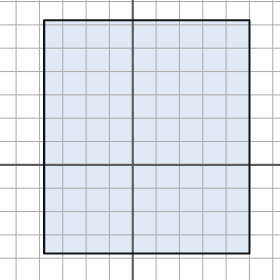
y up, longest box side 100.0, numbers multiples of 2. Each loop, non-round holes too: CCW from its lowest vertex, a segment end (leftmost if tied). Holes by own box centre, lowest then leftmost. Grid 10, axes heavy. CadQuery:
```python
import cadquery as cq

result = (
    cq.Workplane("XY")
    .moveTo(-38.0, -38.0)
    .lineTo(50.0, -38.0)
    .lineTo(50.0, 62.0)
    .lineTo(-38.0, 62.0)
    .close()
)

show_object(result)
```